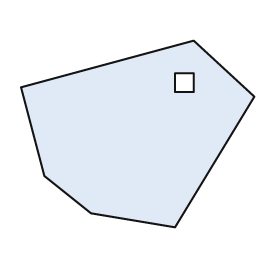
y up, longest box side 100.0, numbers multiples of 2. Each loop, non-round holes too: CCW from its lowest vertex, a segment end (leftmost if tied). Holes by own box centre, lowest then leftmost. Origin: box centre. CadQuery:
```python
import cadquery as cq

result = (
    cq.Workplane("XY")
    .moveTo(16.0, -40.0)
    .lineTo(50.0, 16.0)
    .lineTo(24.0, 40.0)
    .lineTo(-50.0, 20.0)
    .lineTo(-40.0, -18.0)
    .lineTo(-20.0, -34.0)
    .close()
    .moveTo(16.0, 18.0)
    .lineTo(24.0, 18.0)
    .lineTo(24.0, 26.0)
    .lineTo(16.0, 26.0)
    .close()
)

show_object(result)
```